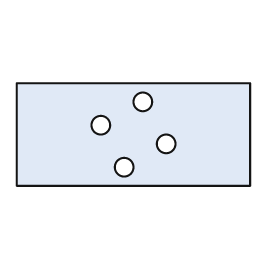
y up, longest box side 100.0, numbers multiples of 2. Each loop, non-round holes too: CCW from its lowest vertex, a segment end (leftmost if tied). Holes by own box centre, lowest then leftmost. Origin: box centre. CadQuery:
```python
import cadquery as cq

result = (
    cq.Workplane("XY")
    .moveTo(-50.0, -22.0)
    .lineTo(50.0, -22.0)
    .lineTo(50.0, 22.0)
    .lineTo(-50.0, 22.0)
    .close()
    .moveTo(-4.0, -14.0)
    .circle(4.0)
    .moveTo(14.0, -4.0)
    .circle(4.0)
    .moveTo(-14.0, 4.0)
    .circle(4.0)
    .moveTo(4.0, 14.0)
    .circle(4.0)
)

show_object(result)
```